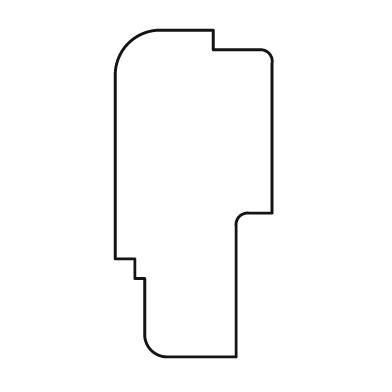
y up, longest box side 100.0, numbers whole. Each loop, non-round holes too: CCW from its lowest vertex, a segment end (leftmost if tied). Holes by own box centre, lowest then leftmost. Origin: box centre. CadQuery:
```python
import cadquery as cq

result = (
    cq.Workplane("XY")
    .moveTo(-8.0, -50.0)
    .lineTo(13.0, -50.0)
    .lineTo(13.0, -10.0)
    .threePointArc((14.0, -7.0), (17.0, -6.0))
    .lineTo(24.0, -6.0)
    .lineTo(24.0, 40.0)
    .threePointArc((23.0, 43.0), (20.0, 44.0))
    .lineTo(6.0, 44.0)
    .lineTo(6.0, 50.0)
    .lineTo(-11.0, 50.0)
    .threePointArc((-20.0, 46.0), (-24.0, 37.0))
    .lineTo(-24.0, -20.0)
    .lineTo(-18.0, -20.0)
    .lineTo(-18.0, -26.0)
    .lineTo(-15.0, -26.0)
    .lineTo(-15.0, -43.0)
    .threePointArc((-13.0, -48.0), (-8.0, -50.0))
    .close()
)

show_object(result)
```